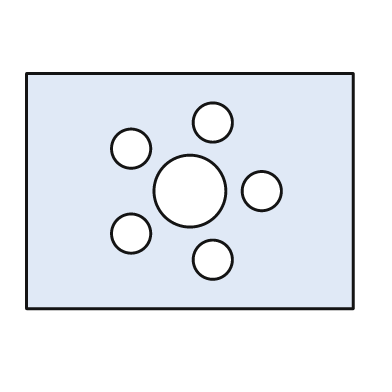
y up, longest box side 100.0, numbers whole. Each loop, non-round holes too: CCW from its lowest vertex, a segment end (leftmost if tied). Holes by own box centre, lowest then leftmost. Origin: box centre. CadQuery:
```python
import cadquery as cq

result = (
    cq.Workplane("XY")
    .moveTo(-50.0, -36.0)
    .lineTo(50.0, -36.0)
    .lineTo(50.0, 36.0)
    .lineTo(-50.0, 36.0)
    .close()
    .moveTo(7.0, -21.0)
    .circle(6.0)
    .moveTo(-18.0, -13.0)
    .circle(6.0)
    .moveTo(0.0, 0.0)
    .circle(11.0)
    .moveTo(22.0, 0.0)
    .circle(6.0)
    .moveTo(-18.0, 13.0)
    .circle(6.0)
    .moveTo(7.0, 21.0)
    .circle(6.0)
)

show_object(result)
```